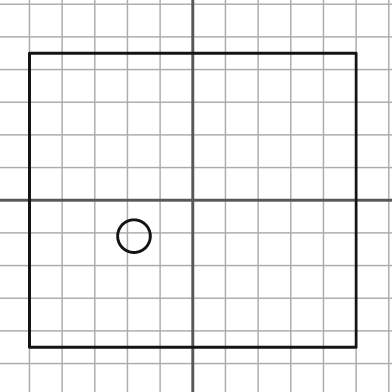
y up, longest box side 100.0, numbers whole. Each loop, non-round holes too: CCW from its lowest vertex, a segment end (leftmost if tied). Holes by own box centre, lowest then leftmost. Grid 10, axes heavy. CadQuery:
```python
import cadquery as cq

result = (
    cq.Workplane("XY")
    .moveTo(-50.0, -45.0)
    .lineTo(50.0, -45.0)
    .lineTo(50.0, 45.0)
    .lineTo(-50.0, 45.0)
    .close()
    .moveTo(-18.0, -11.0)
    .circle(5.0)
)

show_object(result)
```